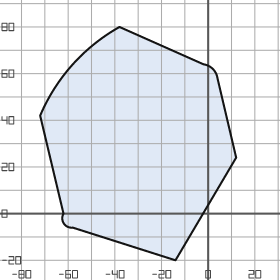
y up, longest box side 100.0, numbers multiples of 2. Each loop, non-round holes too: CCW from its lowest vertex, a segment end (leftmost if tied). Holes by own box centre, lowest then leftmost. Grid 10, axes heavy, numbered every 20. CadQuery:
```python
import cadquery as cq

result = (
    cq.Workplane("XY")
    .moveTo(-14.0, -20.0)
    .lineTo(12.0, 24.0)
    .lineTo(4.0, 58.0)
    .threePointArc((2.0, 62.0), (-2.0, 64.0))
    .lineTo(-38.0, 80.0)
    .threePointArc((-58.0, 64.0), (-72.0, 42.0))
    .lineTo(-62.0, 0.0)
    .threePointArc((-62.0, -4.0), (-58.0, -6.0))
    .close()
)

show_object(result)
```